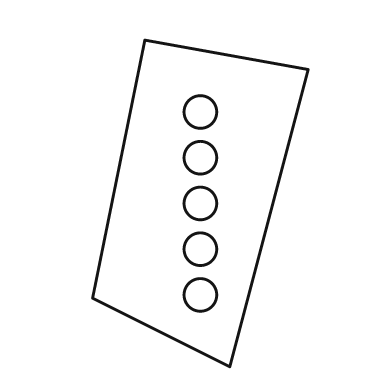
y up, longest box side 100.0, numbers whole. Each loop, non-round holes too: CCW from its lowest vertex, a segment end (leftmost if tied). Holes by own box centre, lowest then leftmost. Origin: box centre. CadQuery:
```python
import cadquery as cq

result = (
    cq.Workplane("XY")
    .moveTo(9.0, -50.0)
    .lineTo(33.0, 41.0)
    .lineTo(-17.0, 50.0)
    .lineTo(-33.0, -29.0)
    .close()
    .moveTo(0.0, -28.0)
    .circle(5.0)
    .moveTo(0.0, -14.0)
    .circle(5.0)
    .moveTo(0.0, 0.0)
    .circle(5.0)
    .moveTo(0.0, 14.0)
    .circle(5.0)
    .moveTo(0.0, 28.0)
    .circle(5.0)
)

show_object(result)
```